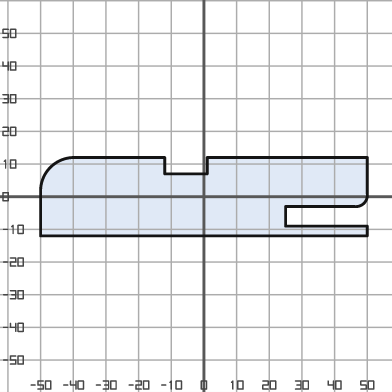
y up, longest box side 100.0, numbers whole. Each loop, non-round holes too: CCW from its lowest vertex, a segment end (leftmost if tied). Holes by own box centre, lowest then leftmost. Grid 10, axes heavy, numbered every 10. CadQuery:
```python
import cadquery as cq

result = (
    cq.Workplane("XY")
    .moveTo(-50.0, -12.0)
    .lineTo(50.0, -12.0)
    .lineTo(50.0, -9.0)
    .lineTo(25.0, -9.0)
    .lineTo(25.0, -3.0)
    .lineTo(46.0, -3.0)
    .threePointArc((49.0, -2.0), (50.0, 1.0))
    .lineTo(50.0, 12.0)
    .lineTo(1.0, 12.0)
    .lineTo(1.0, 7.0)
    .lineTo(-12.0, 7.0)
    .lineTo(-12.0, 12.0)
    .lineTo(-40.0, 12.0)
    .threePointArc((-47.0, 9.0), (-50.0, 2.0))
    .close()
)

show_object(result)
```